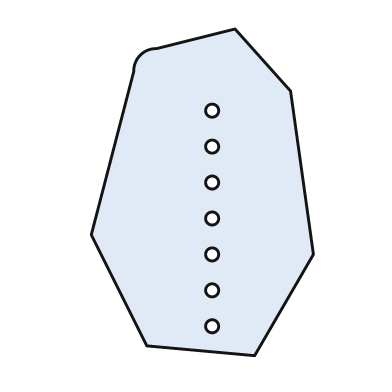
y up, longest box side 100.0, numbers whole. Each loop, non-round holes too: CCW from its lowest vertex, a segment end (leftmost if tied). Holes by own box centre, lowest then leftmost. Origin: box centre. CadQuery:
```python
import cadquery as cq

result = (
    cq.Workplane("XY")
    .moveTo(16.0, -50.0)
    .lineTo(34.0, -19.0)
    .lineTo(27.0, 31.0)
    .lineTo(10.0, 50.0)
    .lineTo(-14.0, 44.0)
    .threePointArc((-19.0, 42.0), (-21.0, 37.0))
    .lineTo(-34.0, -13.0)
    .lineTo(-17.0, -47.0)
    .close()
    .moveTo(3.0, -41.0)
    .circle(2.0)
    .moveTo(3.0, -30.0)
    .circle(2.0)
    .moveTo(3.0, -19.0)
    .circle(2.0)
    .moveTo(3.0, -8.0)
    .circle(2.0)
    .moveTo(3.0, 3.0)
    .circle(2.0)
    .moveTo(3.0, 14.0)
    .circle(2.0)
    .moveTo(3.0, 25.0)
    .circle(2.0)
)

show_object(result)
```